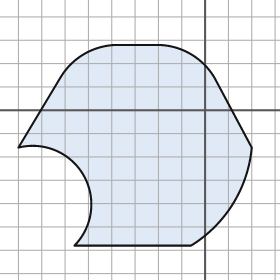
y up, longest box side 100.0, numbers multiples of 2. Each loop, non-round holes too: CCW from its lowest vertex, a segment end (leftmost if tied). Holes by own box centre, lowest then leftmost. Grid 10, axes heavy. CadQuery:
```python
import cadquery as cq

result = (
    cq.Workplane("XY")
    .moveTo(-56.0, -58.0)
    .lineTo(-6.0, -58.0)
    .threePointArc((12.0, -40.0), (20.0, -16.0))
    .lineTo(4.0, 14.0)
    .threePointArc((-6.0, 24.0), (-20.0, 28.0))
    .lineTo(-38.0, 28.0)
    .threePointArc((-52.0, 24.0), (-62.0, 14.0))
    .lineTo(-80.0, -16.0)
    .threePointArc((-52.0, -28.0), (-56.0, -58.0))
    .close()
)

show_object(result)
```